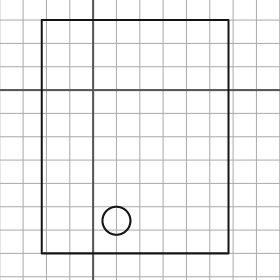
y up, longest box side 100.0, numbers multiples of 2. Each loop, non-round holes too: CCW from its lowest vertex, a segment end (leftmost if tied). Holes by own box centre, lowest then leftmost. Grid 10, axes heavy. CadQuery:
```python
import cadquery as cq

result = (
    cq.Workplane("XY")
    .moveTo(-22.0, -70.0)
    .lineTo(58.0, -70.0)
    .lineTo(58.0, 30.0)
    .lineTo(-22.0, 30.0)
    .close()
    .moveTo(10.0, -56.0)
    .circle(6.0)
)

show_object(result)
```